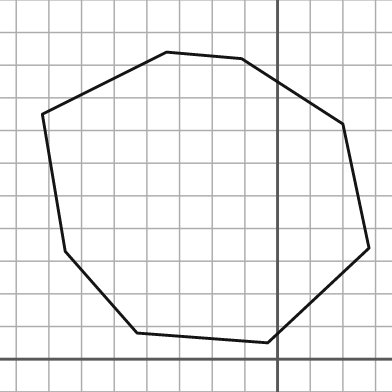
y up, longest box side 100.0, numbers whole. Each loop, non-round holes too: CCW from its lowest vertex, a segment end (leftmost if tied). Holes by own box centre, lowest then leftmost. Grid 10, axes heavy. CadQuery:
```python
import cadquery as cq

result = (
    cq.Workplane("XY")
    .moveTo(-3.0, 5.0)
    .lineTo(28.0, 34.0)
    .lineTo(20.0, 72.0)
    .lineTo(-11.0, 92.0)
    .lineTo(-34.0, 94.0)
    .lineTo(-72.0, 75.0)
    .lineTo(-65.0, 33.0)
    .lineTo(-43.0, 8.0)
    .close()
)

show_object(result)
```